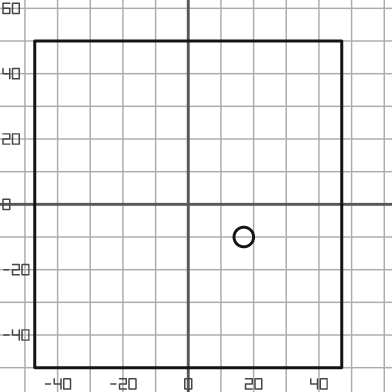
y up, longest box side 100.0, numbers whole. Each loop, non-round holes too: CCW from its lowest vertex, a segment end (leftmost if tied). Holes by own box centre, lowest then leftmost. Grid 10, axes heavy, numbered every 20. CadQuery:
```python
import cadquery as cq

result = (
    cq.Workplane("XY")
    .moveTo(-47.0, -50.0)
    .lineTo(47.0, -50.0)
    .lineTo(47.0, 50.0)
    .lineTo(-47.0, 50.0)
    .close()
    .moveTo(17.0, -10.0)
    .circle(3.0)
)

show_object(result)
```